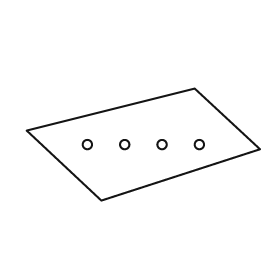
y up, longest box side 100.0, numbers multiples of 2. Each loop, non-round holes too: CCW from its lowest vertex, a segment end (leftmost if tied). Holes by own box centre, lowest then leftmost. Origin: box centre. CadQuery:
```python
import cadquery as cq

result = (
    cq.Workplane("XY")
    .moveTo(-18.0, -24.0)
    .lineTo(50.0, -2.0)
    .lineTo(22.0, 24.0)
    .lineTo(-50.0, 6.0)
    .close()
    .moveTo(-24.0, 0.0)
    .circle(2.0)
    .moveTo(-8.0, 0.0)
    .circle(2.0)
    .moveTo(8.0, 0.0)
    .circle(2.0)
    .moveTo(24.0, 0.0)
    .circle(2.0)
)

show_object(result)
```